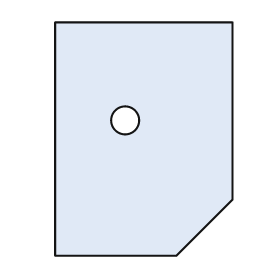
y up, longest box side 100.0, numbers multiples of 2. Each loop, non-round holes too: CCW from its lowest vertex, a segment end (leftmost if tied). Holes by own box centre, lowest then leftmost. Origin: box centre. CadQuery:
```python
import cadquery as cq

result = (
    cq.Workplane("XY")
    .moveTo(-38.0, -50.0)
    .lineTo(14.0, -50.0)
    .lineTo(38.0, -26.0)
    .lineTo(38.0, 50.0)
    .lineTo(-38.0, 50.0)
    .close()
    .moveTo(-8.0, 8.0)
    .circle(6.0)
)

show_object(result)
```